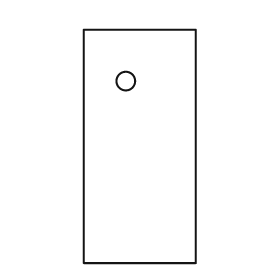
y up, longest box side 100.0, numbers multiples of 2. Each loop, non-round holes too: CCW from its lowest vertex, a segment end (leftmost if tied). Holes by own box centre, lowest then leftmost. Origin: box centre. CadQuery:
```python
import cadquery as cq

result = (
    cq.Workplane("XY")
    .moveTo(-24.0, -50.0)
    .lineTo(24.0, -50.0)
    .lineTo(24.0, 50.0)
    .lineTo(-24.0, 50.0)
    .close()
    .moveTo(-6.0, 28.0)
    .circle(4.0)
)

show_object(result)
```